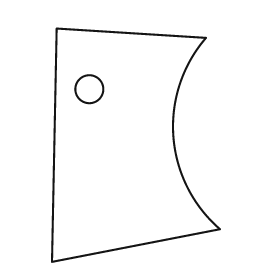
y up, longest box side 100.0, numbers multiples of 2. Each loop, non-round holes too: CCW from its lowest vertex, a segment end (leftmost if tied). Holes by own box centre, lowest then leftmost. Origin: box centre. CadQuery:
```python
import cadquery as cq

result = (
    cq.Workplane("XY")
    .moveTo(-36.0, -50.0)
    .lineTo(36.0, -36.0)
    .threePointArc((16.0, 4.0), (30.0, 46.0))
    .lineTo(-34.0, 50.0)
    .close()
    .moveTo(-20.0, 24.0)
    .circle(6.0)
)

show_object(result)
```